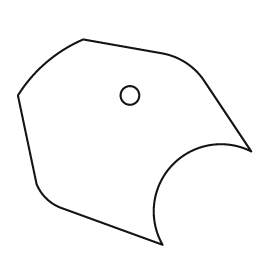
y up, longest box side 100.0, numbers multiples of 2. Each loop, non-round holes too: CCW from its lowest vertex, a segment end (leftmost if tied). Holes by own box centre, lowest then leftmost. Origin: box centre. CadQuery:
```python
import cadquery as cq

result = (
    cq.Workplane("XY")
    .moveTo(12.0, -44.0)
    .threePointArc((16.0, -10.0), (50.0, -4.0))
    .lineTo(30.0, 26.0)
    .threePointArc((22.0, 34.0), (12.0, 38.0))
    .lineTo(-22.0, 44.0)
    .threePointArc((-38.0, 34.0), (-50.0, 20.0))
    .lineTo(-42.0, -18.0)
    .threePointArc((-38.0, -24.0), (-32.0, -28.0))
    .close()
    .moveTo(-2.0, 20.0)
    .circle(4.0)
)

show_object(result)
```